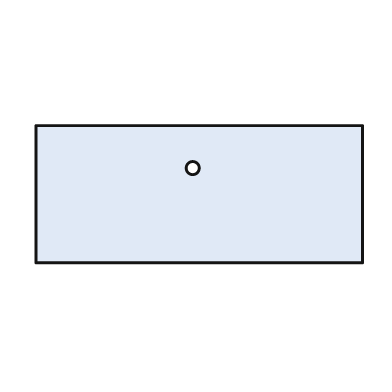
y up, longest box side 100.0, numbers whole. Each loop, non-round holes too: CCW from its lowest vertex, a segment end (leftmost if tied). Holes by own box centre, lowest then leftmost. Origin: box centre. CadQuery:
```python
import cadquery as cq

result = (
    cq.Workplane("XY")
    .moveTo(-50.0, -21.0)
    .lineTo(50.0, -21.0)
    .lineTo(50.0, 21.0)
    .lineTo(-50.0, 21.0)
    .close()
    .moveTo(-2.0, 8.0)
    .circle(2.0)
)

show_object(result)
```